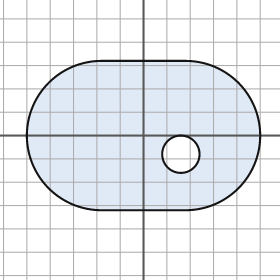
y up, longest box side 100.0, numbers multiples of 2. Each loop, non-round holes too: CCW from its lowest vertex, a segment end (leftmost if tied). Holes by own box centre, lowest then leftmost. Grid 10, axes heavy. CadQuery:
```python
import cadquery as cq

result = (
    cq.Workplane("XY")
    .moveTo(-18.0, -32.0)
    .lineTo(18.0, -32.0)
    .threePointArc((50.0, 0.0), (18.0, 32.0))
    .lineTo(-18.0, 32.0)
    .threePointArc((-50.0, 0.0), (-18.0, -32.0))
    .close()
    .moveTo(16.0, -8.0)
    .circle(8.0)
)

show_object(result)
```